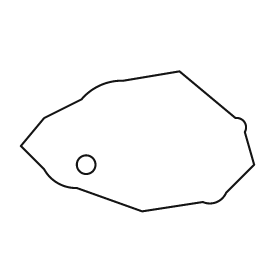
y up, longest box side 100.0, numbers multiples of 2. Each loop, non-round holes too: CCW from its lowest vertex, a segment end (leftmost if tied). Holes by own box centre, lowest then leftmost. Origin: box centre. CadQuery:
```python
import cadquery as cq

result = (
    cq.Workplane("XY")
    .moveTo(2.0, -30.0)
    .lineTo(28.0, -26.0)
    .threePointArc((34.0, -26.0), (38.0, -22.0))
    .lineTo(50.0, -10.0)
    .lineTo(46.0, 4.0)
    .threePointArc((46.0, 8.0), (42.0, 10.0))
    .lineTo(18.0, 30.0)
    .lineTo(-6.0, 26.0)
    .threePointArc((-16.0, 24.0), (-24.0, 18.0))
    .lineTo(-40.0, 10.0)
    .lineTo(-50.0, -2.0)
    .lineTo(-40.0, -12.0)
    .threePointArc((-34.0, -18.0), (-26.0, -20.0))
    .close()
    .moveTo(-22.0, -10.0)
    .circle(4.0)
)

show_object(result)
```